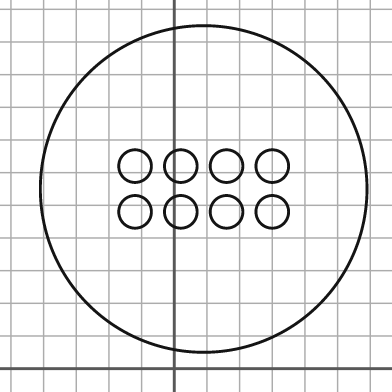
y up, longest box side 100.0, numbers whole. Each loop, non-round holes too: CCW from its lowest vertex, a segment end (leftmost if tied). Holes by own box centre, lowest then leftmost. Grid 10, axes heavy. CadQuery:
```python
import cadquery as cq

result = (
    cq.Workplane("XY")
    .moveTo(9.0, 55.0)
    .circle(50.0)
    .moveTo(-12.0, 48.0)
    .circle(5.0)
    .moveTo(2.0, 48.0)
    .circle(5.0)
    .moveTo(16.0, 48.0)
    .circle(5.0)
    .moveTo(30.0, 48.0)
    .circle(5.0)
    .moveTo(-12.0, 62.0)
    .circle(5.0)
    .moveTo(2.0, 62.0)
    .circle(5.0)
    .moveTo(16.0, 62.0)
    .circle(5.0)
    .moveTo(30.0, 62.0)
    .circle(5.0)
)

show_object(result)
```